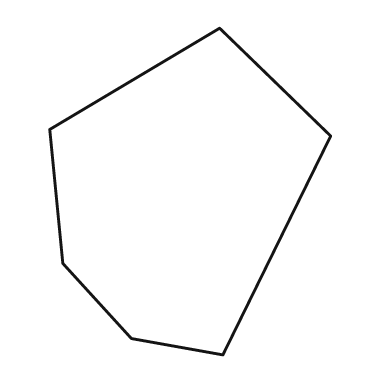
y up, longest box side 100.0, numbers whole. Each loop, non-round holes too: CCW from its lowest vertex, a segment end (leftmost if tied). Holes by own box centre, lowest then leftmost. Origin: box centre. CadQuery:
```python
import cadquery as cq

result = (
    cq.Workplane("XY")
    .moveTo(10.0, -50.0)
    .lineTo(43.0, 17.0)
    .lineTo(9.0, 50.0)
    .lineTo(-43.0, 19.0)
    .lineTo(-39.0, -22.0)
    .lineTo(-18.0, -45.0)
    .close()
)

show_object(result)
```